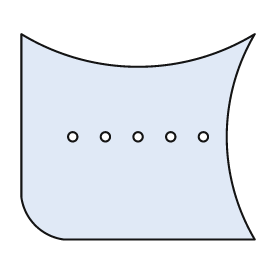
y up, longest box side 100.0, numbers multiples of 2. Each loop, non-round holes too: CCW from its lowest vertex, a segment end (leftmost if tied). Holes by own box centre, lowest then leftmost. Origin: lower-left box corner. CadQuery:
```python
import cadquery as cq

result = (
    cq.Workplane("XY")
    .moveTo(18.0, 0.0)
    .lineTo(100.0, 0.0)
    .threePointArc((88.0, 44.0), (100.0, 88.0))
    .threePointArc((50.0, 74.0), (0.0, 88.0))
    .lineTo(0.0, 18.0)
    .threePointArc((6.0, 6.0), (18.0, 0.0))
    .close()
    .moveTo(22.0, 44.0)
    .circle(2.0)
    .moveTo(36.0, 44.0)
    .circle(2.0)
    .moveTo(50.0, 44.0)
    .circle(2.0)
    .moveTo(64.0, 44.0)
    .circle(2.0)
    .moveTo(78.0, 44.0)
    .circle(2.0)
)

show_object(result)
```